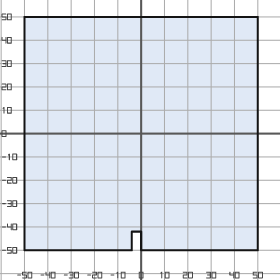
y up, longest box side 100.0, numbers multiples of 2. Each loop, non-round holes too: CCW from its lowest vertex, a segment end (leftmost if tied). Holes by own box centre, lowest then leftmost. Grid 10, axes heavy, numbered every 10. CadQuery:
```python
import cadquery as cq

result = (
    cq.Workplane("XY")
    .moveTo(-50.0, -50.0)
    .lineTo(-4.0, -50.0)
    .lineTo(-4.0, -42.0)
    .lineTo(0.0, -42.0)
    .lineTo(0.0, -50.0)
    .lineTo(50.0, -50.0)
    .lineTo(50.0, 50.0)
    .lineTo(-50.0, 50.0)
    .close()
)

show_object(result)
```